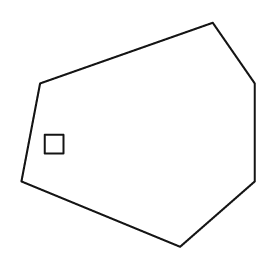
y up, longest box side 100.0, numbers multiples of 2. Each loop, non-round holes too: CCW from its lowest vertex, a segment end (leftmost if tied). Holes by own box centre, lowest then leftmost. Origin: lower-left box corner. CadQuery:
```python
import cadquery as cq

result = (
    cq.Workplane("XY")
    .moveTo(68.0, 0.0)
    .lineTo(100.0, 28.0)
    .lineTo(100.0, 70.0)
    .lineTo(82.0, 96.0)
    .lineTo(8.0, 70.0)
    .lineTo(0.0, 28.0)
    .close()
    .moveTo(10.0, 40.0)
    .lineTo(18.0, 40.0)
    .lineTo(18.0, 48.0)
    .lineTo(10.0, 48.0)
    .close()
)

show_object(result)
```